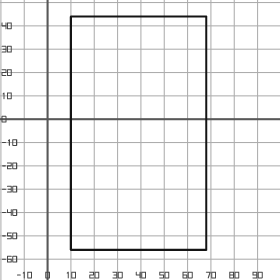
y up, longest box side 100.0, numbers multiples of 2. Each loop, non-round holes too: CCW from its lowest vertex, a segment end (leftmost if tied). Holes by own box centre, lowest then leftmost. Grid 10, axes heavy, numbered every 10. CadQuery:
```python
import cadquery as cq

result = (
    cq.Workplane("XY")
    .moveTo(10.0, -56.0)
    .lineTo(68.0, -56.0)
    .lineTo(68.0, 44.0)
    .lineTo(10.0, 44.0)
    .close()
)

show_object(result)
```